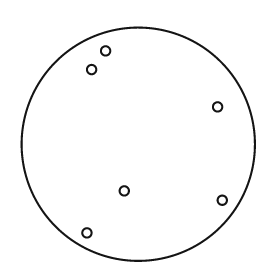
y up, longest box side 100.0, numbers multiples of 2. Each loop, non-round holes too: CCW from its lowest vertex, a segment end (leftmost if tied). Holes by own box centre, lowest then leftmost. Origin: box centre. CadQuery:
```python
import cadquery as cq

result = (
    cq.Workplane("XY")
    .moveTo(0.0, 0.0)
    .circle(50.0)
    .moveTo(-22.0, -38.0)
    .circle(2.0)
    .moveTo(36.0, -24.0)
    .circle(2.0)
    .moveTo(-6.0, -20.0)
    .circle(2.0)
    .moveTo(34.0, 16.0)
    .circle(2.0)
    .moveTo(-20.0, 32.0)
    .circle(2.0)
    .moveTo(-14.0, 40.0)
    .circle(2.0)
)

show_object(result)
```